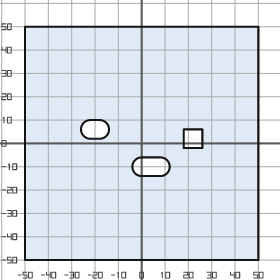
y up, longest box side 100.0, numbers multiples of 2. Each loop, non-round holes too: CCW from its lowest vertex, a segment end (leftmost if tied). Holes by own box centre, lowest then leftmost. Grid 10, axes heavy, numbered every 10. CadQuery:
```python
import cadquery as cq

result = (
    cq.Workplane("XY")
    .moveTo(-50.0, -50.0)
    .lineTo(50.0, -50.0)
    .lineTo(50.0, 50.0)
    .lineTo(-50.0, 50.0)
    .close()
    .moveTo(0.0, -14.0)
    .lineTo(8.0, -14.0)
    .threePointArc((12.0, -10.0), (8.0, -6.0))
    .lineTo(0.0, -6.0)
    .threePointArc((-4.0, -10.0), (0.0, -14.0))
    .close()
    .moveTo(18.0, -2.0)
    .lineTo(26.0, -2.0)
    .lineTo(26.0, 6.0)
    .lineTo(18.0, 6.0)
    .close()
    .moveTo(-22.0, 2.0)
    .lineTo(-18.0, 2.0)
    .threePointArc((-14.0, 6.0), (-18.0, 10.0))
    .lineTo(-22.0, 10.0)
    .threePointArc((-26.0, 6.0), (-22.0, 2.0))
    .close()
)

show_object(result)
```